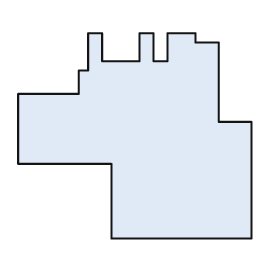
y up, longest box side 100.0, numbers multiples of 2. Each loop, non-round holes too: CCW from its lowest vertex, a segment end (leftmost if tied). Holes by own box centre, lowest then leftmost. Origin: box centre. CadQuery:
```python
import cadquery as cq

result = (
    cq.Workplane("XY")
    .moveTo(-10.0, -44.0)
    .lineTo(50.0, -44.0)
    .lineTo(50.0, 6.0)
    .lineTo(36.0, 6.0)
    .lineTo(36.0, 40.0)
    .lineTo(26.0, 40.0)
    .lineTo(26.0, 44.0)
    .lineTo(14.0, 44.0)
    .lineTo(14.0, 32.0)
    .lineTo(8.0, 32.0)
    .lineTo(8.0, 44.0)
    .lineTo(2.0, 44.0)
    .lineTo(2.0, 32.0)
    .lineTo(-14.0, 32.0)
    .lineTo(-14.0, 44.0)
    .lineTo(-20.0, 44.0)
    .lineTo(-20.0, 28.0)
    .lineTo(-24.0, 28.0)
    .lineTo(-24.0, 18.0)
    .lineTo(-50.0, 18.0)
    .lineTo(-50.0, -12.0)
    .lineTo(-10.0, -12.0)
    .close()
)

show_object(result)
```